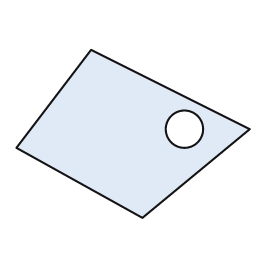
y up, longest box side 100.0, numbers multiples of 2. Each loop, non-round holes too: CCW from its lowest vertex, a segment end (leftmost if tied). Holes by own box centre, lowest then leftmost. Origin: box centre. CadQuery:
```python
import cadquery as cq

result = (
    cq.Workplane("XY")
    .moveTo(4.0, -36.0)
    .lineTo(50.0, 2.0)
    .lineTo(-18.0, 36.0)
    .lineTo(-50.0, -6.0)
    .close()
    .moveTo(22.0, 2.0)
    .circle(8.0)
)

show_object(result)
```